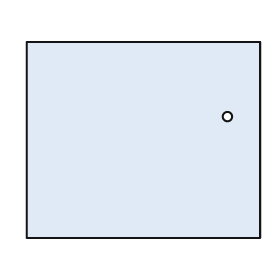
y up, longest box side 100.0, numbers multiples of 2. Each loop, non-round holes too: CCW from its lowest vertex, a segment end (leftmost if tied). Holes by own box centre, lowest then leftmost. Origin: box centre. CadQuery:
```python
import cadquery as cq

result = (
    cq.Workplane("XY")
    .moveTo(-50.0, -42.0)
    .lineTo(50.0, -42.0)
    .lineTo(50.0, 42.0)
    .lineTo(-50.0, 42.0)
    .close()
    .moveTo(36.0, 10.0)
    .circle(2.0)
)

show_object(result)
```